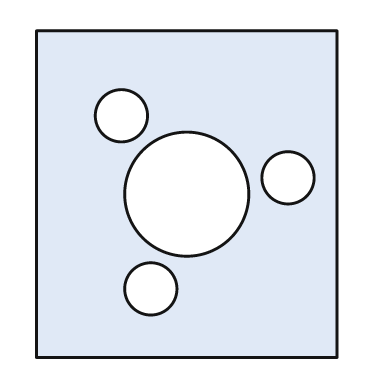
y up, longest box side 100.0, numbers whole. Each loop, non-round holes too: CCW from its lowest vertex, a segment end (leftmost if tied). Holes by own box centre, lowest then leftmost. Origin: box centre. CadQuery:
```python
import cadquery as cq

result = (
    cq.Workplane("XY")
    .moveTo(-46.0, -50.0)
    .lineTo(46.0, -50.0)
    .lineTo(46.0, 50.0)
    .lineTo(-46.0, 50.0)
    .close()
    .moveTo(-11.0, -29.0)
    .circle(8.0)
    .moveTo(0.0, 0.0)
    .circle(19.0)
    .moveTo(31.0, 5.0)
    .circle(8.0)
    .moveTo(-20.0, 24.0)
    .circle(8.0)
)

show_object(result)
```